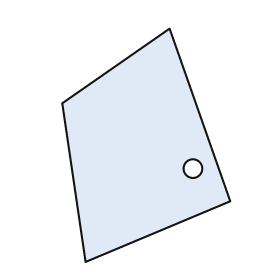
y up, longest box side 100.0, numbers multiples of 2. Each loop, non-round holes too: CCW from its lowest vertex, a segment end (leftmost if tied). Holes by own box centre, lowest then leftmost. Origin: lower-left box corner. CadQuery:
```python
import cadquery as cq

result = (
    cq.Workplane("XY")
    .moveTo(10.0, 0.0)
    .lineTo(72.0, 26.0)
    .lineTo(46.0, 100.0)
    .lineTo(0.0, 68.0)
    .close()
    .moveTo(56.0, 40.0)
    .circle(4.0)
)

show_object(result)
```